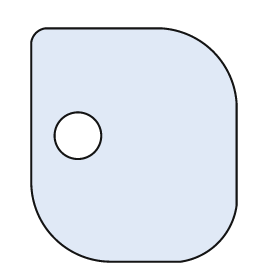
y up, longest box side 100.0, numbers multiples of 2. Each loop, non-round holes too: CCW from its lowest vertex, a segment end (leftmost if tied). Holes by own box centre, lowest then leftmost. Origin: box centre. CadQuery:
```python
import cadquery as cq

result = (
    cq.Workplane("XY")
    .moveTo(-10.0, -50.0)
    .lineTo(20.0, -50.0)
    .threePointArc((36.0, -42.0), (44.0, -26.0))
    .lineTo(44.0, 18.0)
    .threePointArc((34.0, 40.0), (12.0, 50.0))
    .lineTo(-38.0, 50.0)
    .threePointArc((-42.0, 48.0), (-44.0, 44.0))
    .lineTo(-44.0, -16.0)
    .threePointArc((-34.0, -40.0), (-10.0, -50.0))
    .close()
    .moveTo(-24.0, 4.0)
    .circle(10.0)
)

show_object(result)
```